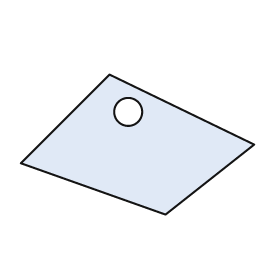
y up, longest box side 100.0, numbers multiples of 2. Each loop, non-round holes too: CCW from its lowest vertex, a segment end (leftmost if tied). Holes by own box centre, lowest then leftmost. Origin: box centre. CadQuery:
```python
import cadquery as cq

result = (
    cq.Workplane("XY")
    .moveTo(12.0, -30.0)
    .lineTo(50.0, 0.0)
    .lineTo(-12.0, 30.0)
    .lineTo(-50.0, -8.0)
    .close()
    .moveTo(-4.0, 14.0)
    .circle(6.0)
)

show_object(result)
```